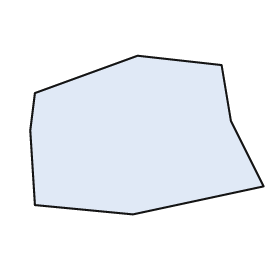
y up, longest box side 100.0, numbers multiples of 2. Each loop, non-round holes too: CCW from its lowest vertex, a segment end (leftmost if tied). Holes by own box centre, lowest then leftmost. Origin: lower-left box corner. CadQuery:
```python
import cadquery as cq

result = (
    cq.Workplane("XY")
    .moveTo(44.0, 0.0)
    .lineTo(100.0, 12.0)
    .lineTo(86.0, 40.0)
    .lineTo(82.0, 64.0)
    .lineTo(46.0, 68.0)
    .lineTo(2.0, 52.0)
    .lineTo(0.0, 36.0)
    .lineTo(2.0, 4.0)
    .close()
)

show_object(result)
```